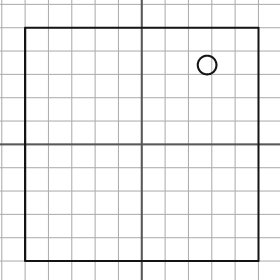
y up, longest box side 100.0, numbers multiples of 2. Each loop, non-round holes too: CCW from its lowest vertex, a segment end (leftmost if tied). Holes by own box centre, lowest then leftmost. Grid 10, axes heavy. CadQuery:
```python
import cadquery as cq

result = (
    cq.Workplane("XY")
    .moveTo(-50.0, -50.0)
    .lineTo(50.0, -50.0)
    .lineTo(50.0, 50.0)
    .lineTo(-50.0, 50.0)
    .close()
    .moveTo(28.0, 34.0)
    .circle(4.0)
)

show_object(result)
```